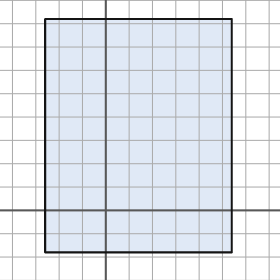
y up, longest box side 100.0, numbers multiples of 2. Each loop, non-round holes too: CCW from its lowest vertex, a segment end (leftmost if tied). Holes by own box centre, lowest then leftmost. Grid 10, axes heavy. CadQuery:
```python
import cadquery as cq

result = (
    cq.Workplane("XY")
    .moveTo(-26.0, -18.0)
    .lineTo(54.0, -18.0)
    .lineTo(54.0, 82.0)
    .lineTo(-26.0, 82.0)
    .close()
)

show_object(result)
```